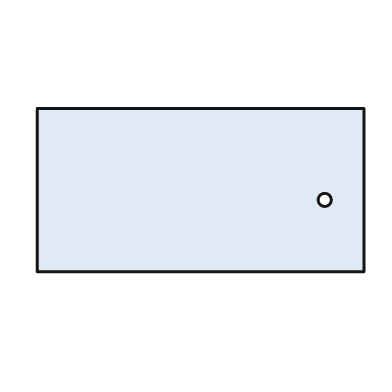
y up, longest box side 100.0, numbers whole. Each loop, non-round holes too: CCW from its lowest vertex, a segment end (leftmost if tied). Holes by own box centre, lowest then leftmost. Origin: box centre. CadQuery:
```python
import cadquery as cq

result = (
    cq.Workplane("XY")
    .moveTo(-50.0, -25.0)
    .lineTo(50.0, -25.0)
    .lineTo(50.0, 25.0)
    .lineTo(-50.0, 25.0)
    .close()
    .moveTo(38.0, -3.0)
    .circle(2.0)
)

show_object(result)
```